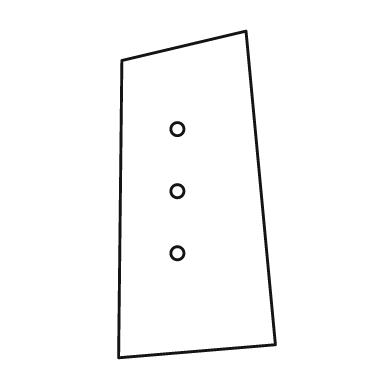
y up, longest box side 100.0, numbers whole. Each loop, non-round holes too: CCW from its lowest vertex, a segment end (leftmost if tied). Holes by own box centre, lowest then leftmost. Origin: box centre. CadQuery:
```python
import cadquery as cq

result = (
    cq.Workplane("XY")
    .moveTo(-24.0, -50.0)
    .lineTo(24.0, -46.0)
    .lineTo(15.0, 50.0)
    .lineTo(-23.0, 41.0)
    .close()
    .moveTo(-6.0, -18.0)
    .circle(2.0)
    .moveTo(-6.0, 1.0)
    .circle(2.0)
    .moveTo(-6.0, 20.0)
    .circle(2.0)
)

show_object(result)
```